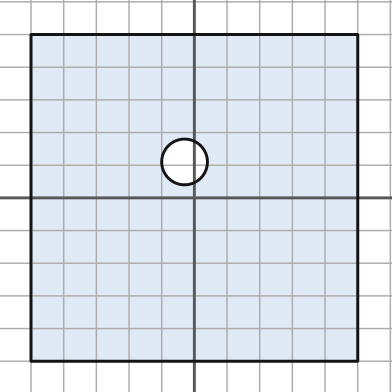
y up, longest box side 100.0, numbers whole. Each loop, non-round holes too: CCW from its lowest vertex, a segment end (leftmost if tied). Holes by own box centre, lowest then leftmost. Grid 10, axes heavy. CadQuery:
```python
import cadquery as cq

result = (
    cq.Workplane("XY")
    .moveTo(-50.0, -50.0)
    .lineTo(50.0, -50.0)
    .lineTo(50.0, 50.0)
    .lineTo(-50.0, 50.0)
    .close()
    .moveTo(-3.0, 11.0)
    .circle(7.0)
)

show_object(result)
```